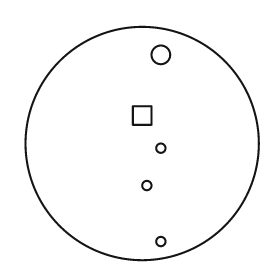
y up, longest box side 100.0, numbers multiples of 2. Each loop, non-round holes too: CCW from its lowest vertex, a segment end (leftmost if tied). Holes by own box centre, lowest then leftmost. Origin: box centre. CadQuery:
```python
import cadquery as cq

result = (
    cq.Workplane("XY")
    .moveTo(0.0, 0.0)
    .circle(50.0)
    .moveTo(8.0, -42.0)
    .circle(2.0)
    .moveTo(2.0, -18.0)
    .circle(2.0)
    .moveTo(8.0, -2.0)
    .circle(2.0)
    .moveTo(-4.0, 8.0)
    .lineTo(4.0, 8.0)
    .lineTo(4.0, 16.0)
    .lineTo(-4.0, 16.0)
    .close()
    .moveTo(8.0, 38.0)
    .circle(4.0)
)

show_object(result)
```